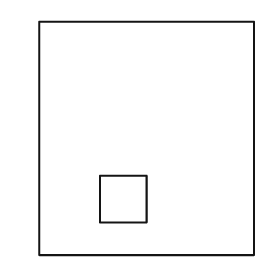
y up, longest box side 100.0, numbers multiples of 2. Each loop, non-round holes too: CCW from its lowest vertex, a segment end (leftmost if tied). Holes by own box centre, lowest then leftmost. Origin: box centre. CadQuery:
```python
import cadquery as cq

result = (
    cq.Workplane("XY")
    .moveTo(-46.0, -50.0)
    .lineTo(46.0, -50.0)
    .lineTo(46.0, 50.0)
    .lineTo(-46.0, 50.0)
    .close()
    .moveTo(-20.0, -36.0)
    .lineTo(0.0, -36.0)
    .lineTo(0.0, -16.0)
    .lineTo(-20.0, -16.0)
    .close()
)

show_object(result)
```